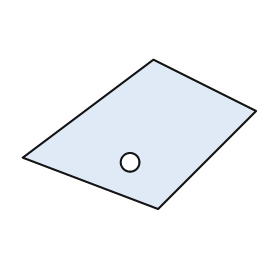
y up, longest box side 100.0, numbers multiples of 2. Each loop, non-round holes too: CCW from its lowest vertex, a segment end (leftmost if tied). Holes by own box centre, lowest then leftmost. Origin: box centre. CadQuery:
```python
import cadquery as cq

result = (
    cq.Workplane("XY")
    .moveTo(8.0, -32.0)
    .lineTo(50.0, 10.0)
    .lineTo(6.0, 32.0)
    .lineTo(-50.0, -10.0)
    .close()
    .moveTo(-4.0, -12.0)
    .circle(4.0)
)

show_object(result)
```